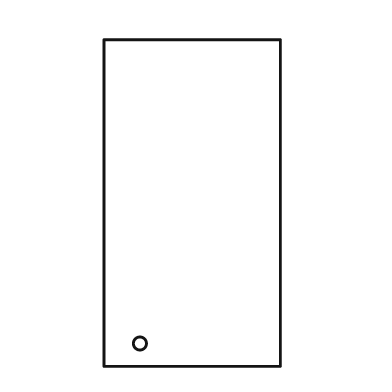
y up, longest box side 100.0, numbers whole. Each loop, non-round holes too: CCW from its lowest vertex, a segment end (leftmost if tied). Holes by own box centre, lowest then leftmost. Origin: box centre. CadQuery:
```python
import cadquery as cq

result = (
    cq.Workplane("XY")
    .moveTo(-27.0, -50.0)
    .lineTo(27.0, -50.0)
    .lineTo(27.0, 50.0)
    .lineTo(-27.0, 50.0)
    .close()
    .moveTo(-16.0, -43.0)
    .circle(2.0)
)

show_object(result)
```